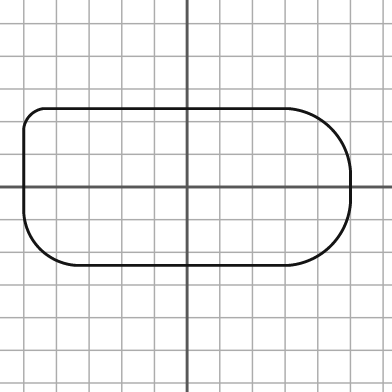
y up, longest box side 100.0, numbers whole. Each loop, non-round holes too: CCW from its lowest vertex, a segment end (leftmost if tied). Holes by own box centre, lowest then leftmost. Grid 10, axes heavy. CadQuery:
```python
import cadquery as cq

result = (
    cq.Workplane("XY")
    .moveTo(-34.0, -24.0)
    .lineTo(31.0, -24.0)
    .threePointArc((44.0, -18.0), (50.0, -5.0))
    .lineTo(50.0, 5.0)
    .threePointArc((44.0, 18.0), (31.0, 24.0))
    .lineTo(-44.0, 24.0)
    .threePointArc((-48.0, 22.0), (-50.0, 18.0))
    .lineTo(-50.0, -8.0)
    .threePointArc((-45.0, -19.0), (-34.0, -24.0))
    .close()
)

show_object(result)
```